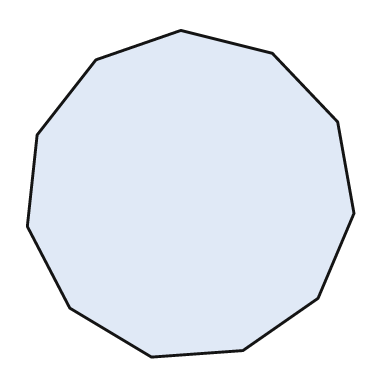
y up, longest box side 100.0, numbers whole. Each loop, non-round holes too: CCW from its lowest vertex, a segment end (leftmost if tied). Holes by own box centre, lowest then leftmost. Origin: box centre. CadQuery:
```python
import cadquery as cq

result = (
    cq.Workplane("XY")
    .moveTo(-12.0, -50.0)
    .lineTo(16.0, -48.0)
    .lineTo(39.0, -32.0)
    .lineTo(50.0, -6.0)
    .lineTo(45.0, 22.0)
    .lineTo(25.0, 43.0)
    .lineTo(-3.0, 50.0)
    .lineTo(-29.0, 41.0)
    .lineTo(-47.0, 18.0)
    .lineTo(-50.0, -10.0)
    .lineTo(-37.0, -35.0)
    .close()
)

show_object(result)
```